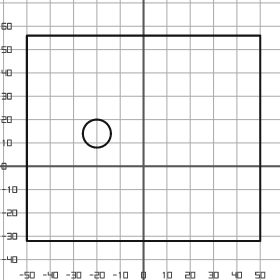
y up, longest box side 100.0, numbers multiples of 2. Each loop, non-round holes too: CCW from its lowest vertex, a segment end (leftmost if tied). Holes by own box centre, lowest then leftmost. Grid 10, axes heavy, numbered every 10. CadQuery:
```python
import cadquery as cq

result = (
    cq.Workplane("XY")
    .moveTo(-50.0, -32.0)
    .lineTo(50.0, -32.0)
    .lineTo(50.0, 56.0)
    .lineTo(-50.0, 56.0)
    .close()
    .moveTo(-20.0, 14.0)
    .circle(6.0)
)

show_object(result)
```